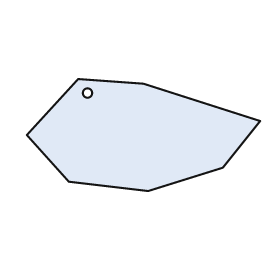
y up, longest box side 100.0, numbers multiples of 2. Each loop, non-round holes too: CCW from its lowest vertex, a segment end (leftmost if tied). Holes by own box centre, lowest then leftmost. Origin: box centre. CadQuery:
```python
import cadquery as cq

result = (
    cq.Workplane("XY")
    .moveTo(2.0, -24.0)
    .lineTo(34.0, -14.0)
    .lineTo(50.0, 6.0)
    .lineTo(0.0, 22.0)
    .lineTo(-28.0, 24.0)
    .lineTo(-50.0, 0.0)
    .lineTo(-32.0, -20.0)
    .close()
    .moveTo(-24.0, 18.0)
    .circle(2.0)
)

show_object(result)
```